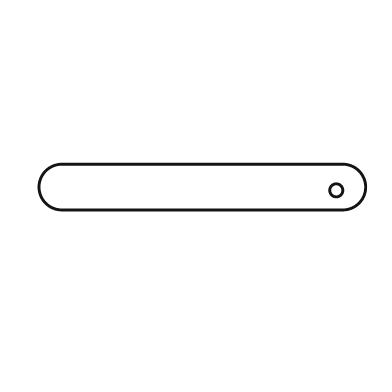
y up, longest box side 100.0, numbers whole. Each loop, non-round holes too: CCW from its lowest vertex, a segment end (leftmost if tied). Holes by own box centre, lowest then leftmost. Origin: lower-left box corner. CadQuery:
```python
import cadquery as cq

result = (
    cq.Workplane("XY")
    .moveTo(7.0, 0.0)
    .lineTo(93.0, 0.0)
    .threePointArc((100.0, 7.0), (93.0, 14.0))
    .lineTo(7.0, 14.0)
    .threePointArc((0.0, 7.0), (7.0, 0.0))
    .close()
    .moveTo(91.0, 6.0)
    .circle(2.0)
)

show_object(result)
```